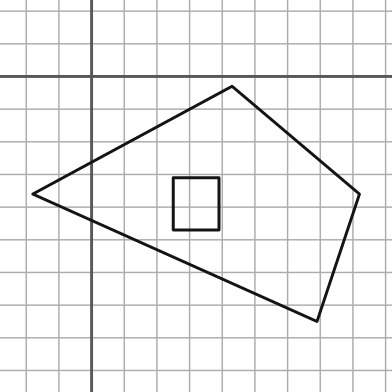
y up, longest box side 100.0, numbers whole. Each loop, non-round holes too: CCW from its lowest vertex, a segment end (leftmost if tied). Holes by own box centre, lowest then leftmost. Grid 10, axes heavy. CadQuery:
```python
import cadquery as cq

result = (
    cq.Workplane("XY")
    .moveTo(69.0, -75.0)
    .lineTo(82.0, -36.0)
    .lineTo(43.0, -3.0)
    .lineTo(-18.0, -36.0)
    .close()
    .moveTo(25.0, -47.0)
    .lineTo(39.0, -47.0)
    .lineTo(39.0, -31.0)
    .lineTo(25.0, -31.0)
    .close()
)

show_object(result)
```